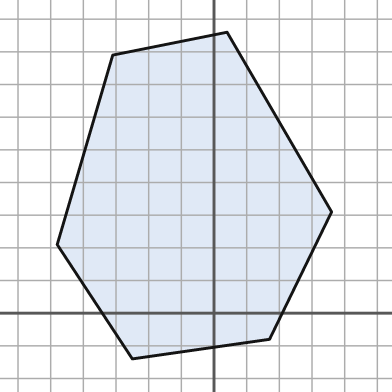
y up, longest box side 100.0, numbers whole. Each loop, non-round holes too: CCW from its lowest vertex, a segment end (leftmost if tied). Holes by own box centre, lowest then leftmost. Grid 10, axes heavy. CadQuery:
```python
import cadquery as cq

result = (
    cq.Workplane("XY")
    .moveTo(-25.0, -14.0)
    .lineTo(17.0, -8.0)
    .lineTo(36.0, 31.0)
    .lineTo(4.0, 86.0)
    .lineTo(-31.0, 79.0)
    .lineTo(-48.0, 21.0)
    .close()
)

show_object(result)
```